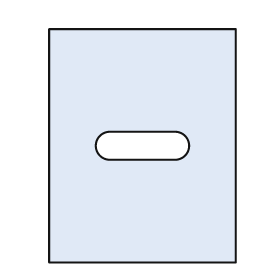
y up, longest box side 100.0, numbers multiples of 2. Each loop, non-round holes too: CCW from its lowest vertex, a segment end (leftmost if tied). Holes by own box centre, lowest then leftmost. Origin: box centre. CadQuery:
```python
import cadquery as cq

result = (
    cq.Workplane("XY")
    .moveTo(-40.0, -50.0)
    .lineTo(40.0, -50.0)
    .lineTo(40.0, 50.0)
    .lineTo(-40.0, 50.0)
    .close()
    .moveTo(-14.0, -6.0)
    .lineTo(14.0, -6.0)
    .threePointArc((20.0, 0.0), (14.0, 6.0))
    .lineTo(-14.0, 6.0)
    .threePointArc((-20.0, 0.0), (-14.0, -6.0))
    .close()
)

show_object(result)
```